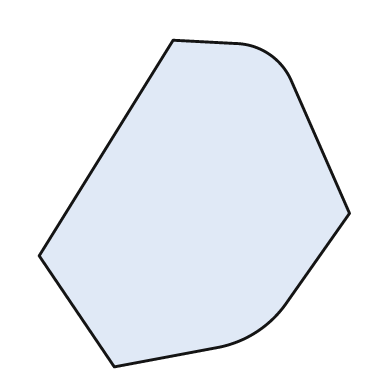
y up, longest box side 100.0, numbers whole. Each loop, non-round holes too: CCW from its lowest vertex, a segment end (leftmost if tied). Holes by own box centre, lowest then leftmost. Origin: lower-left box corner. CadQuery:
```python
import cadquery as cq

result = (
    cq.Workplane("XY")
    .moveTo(23.0, 0.0)
    .lineTo(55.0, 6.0)
    .threePointArc((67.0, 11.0), (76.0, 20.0))
    .lineTo(95.0, 47.0)
    .lineTo(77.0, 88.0)
    .threePointArc((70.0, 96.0), (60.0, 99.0))
    .lineTo(41.0, 100.0)
    .lineTo(0.0, 34.0)
    .close()
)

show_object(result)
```